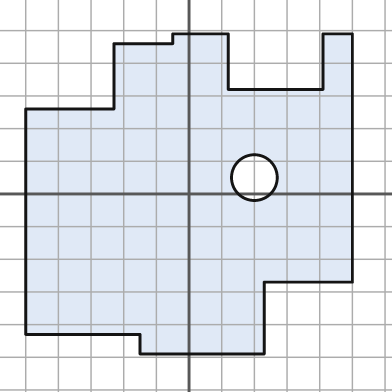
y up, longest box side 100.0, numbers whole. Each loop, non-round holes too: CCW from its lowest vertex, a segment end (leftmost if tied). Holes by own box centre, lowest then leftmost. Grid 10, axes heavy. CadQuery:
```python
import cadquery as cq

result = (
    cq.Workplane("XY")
    .moveTo(-15.0, -49.0)
    .lineTo(23.0, -49.0)
    .lineTo(23.0, -27.0)
    .lineTo(50.0, -27.0)
    .lineTo(50.0, 49.0)
    .lineTo(41.0, 49.0)
    .lineTo(41.0, 32.0)
    .lineTo(12.0, 32.0)
    .lineTo(12.0, 49.0)
    .lineTo(-5.0, 49.0)
    .lineTo(-5.0, 46.0)
    .lineTo(-23.0, 46.0)
    .lineTo(-23.0, 26.0)
    .lineTo(-50.0, 26.0)
    .lineTo(-50.0, -43.0)
    .lineTo(-15.0, -43.0)
    .close()
    .moveTo(20.0, 5.0)
    .circle(7.0)
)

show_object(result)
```